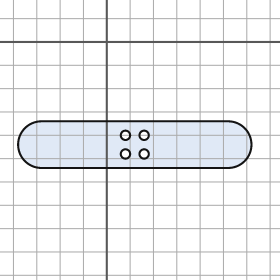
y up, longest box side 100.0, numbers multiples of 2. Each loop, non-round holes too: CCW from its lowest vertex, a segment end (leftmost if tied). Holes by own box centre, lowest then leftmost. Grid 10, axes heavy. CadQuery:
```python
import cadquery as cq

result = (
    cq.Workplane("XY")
    .moveTo(-28.0, -54.0)
    .lineTo(52.0, -54.0)
    .threePointArc((62.0, -44.0), (52.0, -34.0))
    .lineTo(-28.0, -34.0)
    .threePointArc((-38.0, -44.0), (-28.0, -54.0))
    .close()
    .moveTo(8.0, -48.0)
    .circle(2.0)
    .moveTo(16.0, -48.0)
    .circle(2.0)
    .moveTo(8.0, -40.0)
    .circle(2.0)
    .moveTo(16.0, -40.0)
    .circle(2.0)
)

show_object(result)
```